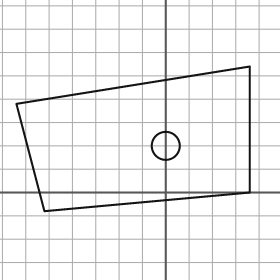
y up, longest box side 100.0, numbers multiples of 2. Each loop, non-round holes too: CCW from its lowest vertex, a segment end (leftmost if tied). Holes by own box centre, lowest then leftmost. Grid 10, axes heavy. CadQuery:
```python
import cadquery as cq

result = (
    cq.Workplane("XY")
    .moveTo(-52.0, -8.0)
    .lineTo(36.0, 0.0)
    .lineTo(36.0, 54.0)
    .lineTo(-64.0, 38.0)
    .close()
    .moveTo(0.0, 20.0)
    .circle(6.0)
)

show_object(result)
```